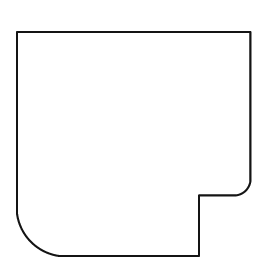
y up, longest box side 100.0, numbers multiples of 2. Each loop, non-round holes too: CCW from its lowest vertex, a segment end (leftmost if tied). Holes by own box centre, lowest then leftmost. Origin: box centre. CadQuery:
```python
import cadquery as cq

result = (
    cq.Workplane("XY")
    .moveTo(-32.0, -48.0)
    .lineTo(28.0, -48.0)
    .lineTo(28.0, -22.0)
    .lineTo(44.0, -22.0)
    .threePointArc((48.0, -20.0), (50.0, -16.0))
    .lineTo(50.0, 48.0)
    .lineTo(-50.0, 48.0)
    .lineTo(-50.0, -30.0)
    .threePointArc((-44.0, -42.0), (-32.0, -48.0))
    .close()
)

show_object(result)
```